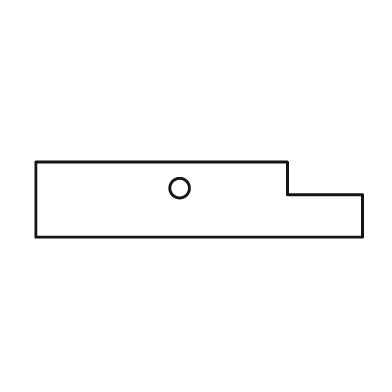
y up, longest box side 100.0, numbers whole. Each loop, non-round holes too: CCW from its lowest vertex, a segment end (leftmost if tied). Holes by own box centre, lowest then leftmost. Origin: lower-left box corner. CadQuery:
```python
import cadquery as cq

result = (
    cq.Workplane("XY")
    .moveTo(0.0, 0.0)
    .lineTo(100.0, 0.0)
    .lineTo(100.0, 13.0)
    .lineTo(77.0, 13.0)
    .lineTo(77.0, 23.0)
    .lineTo(0.0, 23.0)
    .close()
    .moveTo(44.0, 15.0)
    .circle(3.0)
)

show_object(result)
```